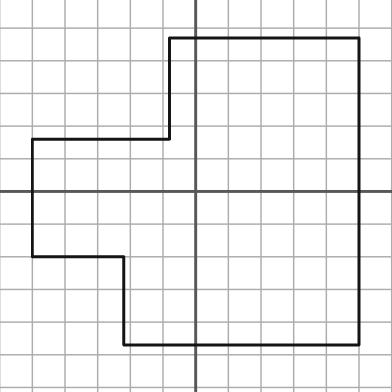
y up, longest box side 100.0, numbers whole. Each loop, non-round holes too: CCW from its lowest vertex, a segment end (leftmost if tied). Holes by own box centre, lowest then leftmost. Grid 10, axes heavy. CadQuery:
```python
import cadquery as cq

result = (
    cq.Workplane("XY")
    .moveTo(-22.0, -47.0)
    .lineTo(50.0, -47.0)
    .lineTo(50.0, 47.0)
    .lineTo(-8.0, 47.0)
    .lineTo(-8.0, 16.0)
    .lineTo(-50.0, 16.0)
    .lineTo(-50.0, -20.0)
    .lineTo(-22.0, -20.0)
    .close()
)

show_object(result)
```